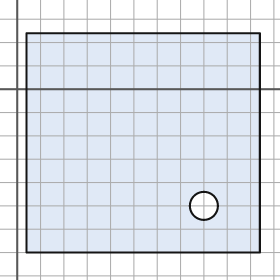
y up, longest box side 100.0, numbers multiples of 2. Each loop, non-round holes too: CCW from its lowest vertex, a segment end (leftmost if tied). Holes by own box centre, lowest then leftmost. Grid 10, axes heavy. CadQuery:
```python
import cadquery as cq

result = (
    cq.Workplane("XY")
    .moveTo(4.0, -70.0)
    .lineTo(104.0, -70.0)
    .lineTo(104.0, 24.0)
    .lineTo(4.0, 24.0)
    .close()
    .moveTo(80.0, -50.0)
    .circle(6.0)
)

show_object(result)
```